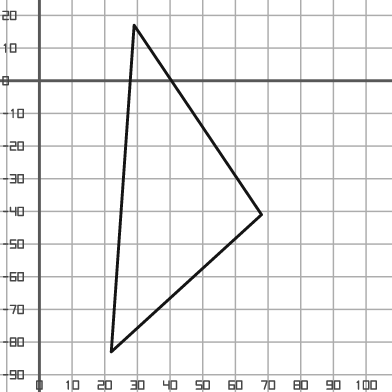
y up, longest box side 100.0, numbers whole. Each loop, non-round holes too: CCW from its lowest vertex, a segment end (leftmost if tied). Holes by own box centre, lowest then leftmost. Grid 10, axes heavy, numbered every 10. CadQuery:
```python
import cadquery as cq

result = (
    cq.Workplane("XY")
    .moveTo(22.0, -83.0)
    .lineTo(68.0, -41.0)
    .lineTo(29.0, 17.0)
    .close()
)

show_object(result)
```